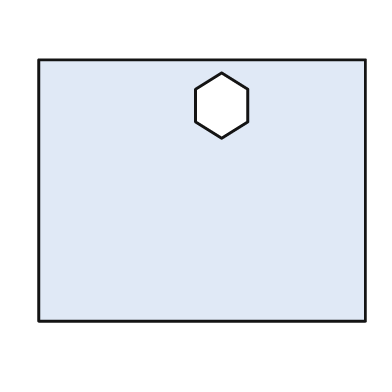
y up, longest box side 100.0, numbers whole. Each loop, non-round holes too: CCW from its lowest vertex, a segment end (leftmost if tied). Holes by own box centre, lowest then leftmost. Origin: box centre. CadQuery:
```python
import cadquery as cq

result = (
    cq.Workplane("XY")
    .moveTo(-50.0, -40.0)
    .lineTo(50.0, -40.0)
    .lineTo(50.0, 40.0)
    .lineTo(-50.0, 40.0)
    .close()
    .moveTo(6.0, 16.0)
    .lineTo(14.0, 21.0)
    .lineTo(14.0, 31.0)
    .lineTo(6.0, 36.0)
    .lineTo(-2.0, 31.0)
    .lineTo(-2.0, 21.0)
    .close()
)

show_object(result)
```